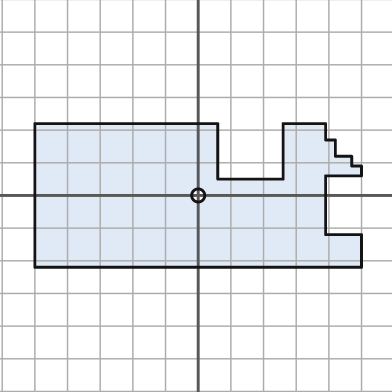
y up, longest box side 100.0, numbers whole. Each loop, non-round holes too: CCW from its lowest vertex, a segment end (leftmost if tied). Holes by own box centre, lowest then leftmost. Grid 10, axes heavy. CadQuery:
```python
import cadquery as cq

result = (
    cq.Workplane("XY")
    .moveTo(-50.0, -22.0)
    .lineTo(50.0, -22.0)
    .lineTo(50.0, -12.0)
    .lineTo(39.0, -12.0)
    .lineTo(39.0, 6.0)
    .lineTo(50.0, 6.0)
    .lineTo(50.0, 9.0)
    .lineTo(47.0, 9.0)
    .lineTo(47.0, 12.0)
    .lineTo(42.0, 12.0)
    .lineTo(42.0, 17.0)
    .lineTo(39.0, 17.0)
    .lineTo(39.0, 22.0)
    .lineTo(26.0, 22.0)
    .lineTo(26.0, 5.0)
    .lineTo(6.0, 5.0)
    .lineTo(6.0, 22.0)
    .lineTo(-50.0, 22.0)
    .close()
    .moveTo(0.0, 0.0)
    .circle(2.0)
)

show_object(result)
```